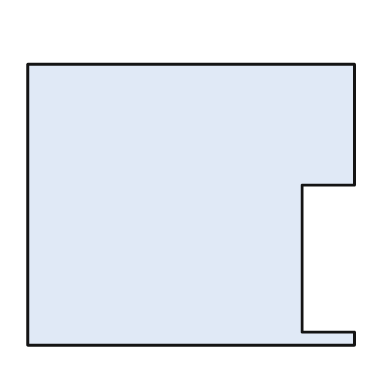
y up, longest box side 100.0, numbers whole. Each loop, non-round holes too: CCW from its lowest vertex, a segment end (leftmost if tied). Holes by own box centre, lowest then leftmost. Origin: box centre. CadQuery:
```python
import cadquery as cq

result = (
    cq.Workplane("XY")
    .moveTo(-50.0, -43.0)
    .lineTo(50.0, -43.0)
    .lineTo(50.0, -39.0)
    .lineTo(34.0, -39.0)
    .lineTo(34.0, 6.0)
    .lineTo(50.0, 6.0)
    .lineTo(50.0, 43.0)
    .lineTo(-50.0, 43.0)
    .close()
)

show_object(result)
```